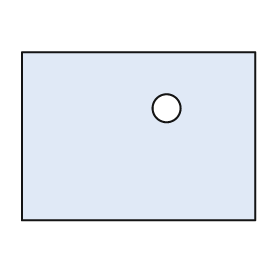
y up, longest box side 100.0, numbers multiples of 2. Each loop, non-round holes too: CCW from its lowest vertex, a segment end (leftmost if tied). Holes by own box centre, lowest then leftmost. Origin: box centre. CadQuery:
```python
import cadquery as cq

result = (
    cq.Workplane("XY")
    .moveTo(-50.0, -36.0)
    .lineTo(50.0, -36.0)
    .lineTo(50.0, 36.0)
    .lineTo(-50.0, 36.0)
    .close()
    .moveTo(12.0, 12.0)
    .circle(6.0)
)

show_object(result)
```